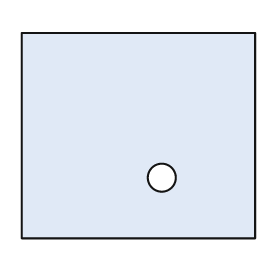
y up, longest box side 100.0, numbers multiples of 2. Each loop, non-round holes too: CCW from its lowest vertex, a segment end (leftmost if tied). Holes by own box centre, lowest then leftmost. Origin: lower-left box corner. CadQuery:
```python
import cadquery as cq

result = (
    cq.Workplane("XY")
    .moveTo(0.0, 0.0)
    .lineTo(100.0, 0.0)
    .lineTo(100.0, 88.0)
    .lineTo(0.0, 88.0)
    .close()
    .moveTo(60.0, 26.0)
    .circle(6.0)
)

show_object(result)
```